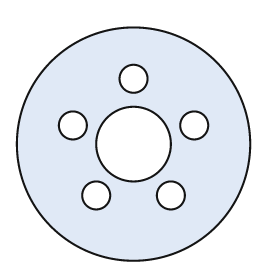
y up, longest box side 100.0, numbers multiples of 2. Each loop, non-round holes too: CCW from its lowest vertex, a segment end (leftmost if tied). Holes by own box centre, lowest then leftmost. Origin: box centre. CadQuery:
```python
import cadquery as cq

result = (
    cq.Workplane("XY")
    .moveTo(0.0, 0.0)
    .circle(50.0)
    .moveTo(-16.0, -22.0)
    .circle(6.0)
    .moveTo(16.0, -22.0)
    .circle(6.0)
    .moveTo(0.0, 0.0)
    .circle(16.0)
    .moveTo(-26.0, 8.0)
    .circle(6.0)
    .moveTo(26.0, 8.0)
    .circle(6.0)
    .moveTo(0.0, 28.0)
    .circle(6.0)
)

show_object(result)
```